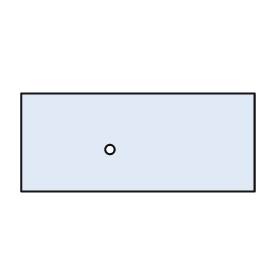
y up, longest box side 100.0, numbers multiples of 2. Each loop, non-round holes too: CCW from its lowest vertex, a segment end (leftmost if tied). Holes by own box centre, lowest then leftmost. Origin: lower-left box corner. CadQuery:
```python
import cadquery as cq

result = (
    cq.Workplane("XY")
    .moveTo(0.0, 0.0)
    .lineTo(100.0, 0.0)
    .lineTo(100.0, 42.0)
    .lineTo(0.0, 42.0)
    .close()
    .moveTo(38.0, 18.0)
    .circle(2.0)
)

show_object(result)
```